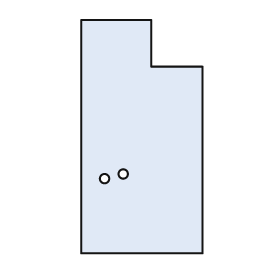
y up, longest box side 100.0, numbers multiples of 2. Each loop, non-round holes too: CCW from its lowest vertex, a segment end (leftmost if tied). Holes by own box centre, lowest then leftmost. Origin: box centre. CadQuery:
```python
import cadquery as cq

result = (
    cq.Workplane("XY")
    .moveTo(-26.0, -50.0)
    .lineTo(26.0, -50.0)
    .lineTo(26.0, 30.0)
    .lineTo(4.0, 30.0)
    .lineTo(4.0, 50.0)
    .lineTo(-26.0, 50.0)
    .close()
    .moveTo(-16.0, -18.0)
    .circle(2.0)
    .moveTo(-8.0, -16.0)
    .circle(2.0)
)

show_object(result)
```